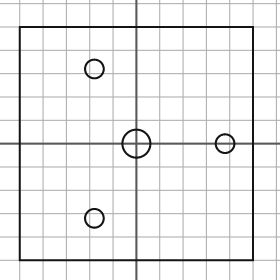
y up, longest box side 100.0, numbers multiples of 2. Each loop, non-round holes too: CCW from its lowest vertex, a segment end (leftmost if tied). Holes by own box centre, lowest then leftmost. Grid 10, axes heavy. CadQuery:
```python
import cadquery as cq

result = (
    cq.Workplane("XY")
    .moveTo(-50.0, -50.0)
    .lineTo(50.0, -50.0)
    .lineTo(50.0, 50.0)
    .lineTo(-50.0, 50.0)
    .close()
    .moveTo(-18.0, -32.0)
    .circle(4.0)
    .moveTo(0.0, 0.0)
    .circle(6.0)
    .moveTo(38.0, 0.0)
    .circle(4.0)
    .moveTo(-18.0, 32.0)
    .circle(4.0)
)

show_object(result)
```